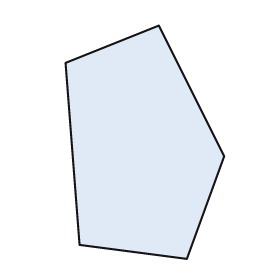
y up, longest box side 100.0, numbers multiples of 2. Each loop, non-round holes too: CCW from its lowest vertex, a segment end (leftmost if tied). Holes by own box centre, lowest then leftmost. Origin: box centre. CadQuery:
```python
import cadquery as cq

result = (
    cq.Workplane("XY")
    .moveTo(18.0, -50.0)
    .lineTo(34.0, -6.0)
    .lineTo(6.0, 50.0)
    .lineTo(-34.0, 34.0)
    .lineTo(-28.0, -44.0)
    .close()
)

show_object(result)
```